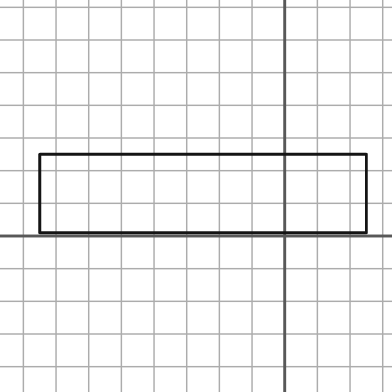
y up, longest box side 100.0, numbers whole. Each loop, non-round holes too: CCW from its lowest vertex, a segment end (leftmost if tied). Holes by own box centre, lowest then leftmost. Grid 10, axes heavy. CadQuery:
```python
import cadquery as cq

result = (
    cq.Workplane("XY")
    .moveTo(-75.0, 1.0)
    .lineTo(25.0, 1.0)
    .lineTo(25.0, 25.0)
    .lineTo(-75.0, 25.0)
    .close()
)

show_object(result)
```